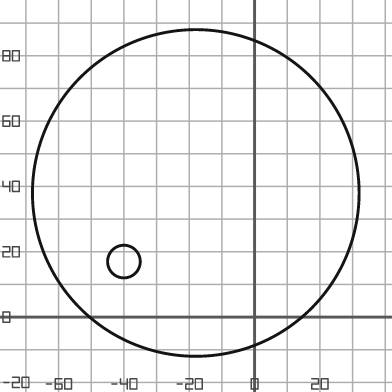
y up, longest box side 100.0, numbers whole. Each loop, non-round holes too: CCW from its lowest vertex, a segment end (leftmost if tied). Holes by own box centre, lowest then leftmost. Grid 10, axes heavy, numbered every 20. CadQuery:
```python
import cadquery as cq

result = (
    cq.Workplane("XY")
    .moveTo(-18.0, 38.0)
    .circle(50.0)
    .moveTo(-40.0, 17.0)
    .circle(5.0)
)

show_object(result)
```